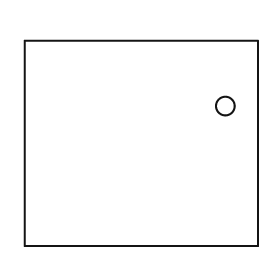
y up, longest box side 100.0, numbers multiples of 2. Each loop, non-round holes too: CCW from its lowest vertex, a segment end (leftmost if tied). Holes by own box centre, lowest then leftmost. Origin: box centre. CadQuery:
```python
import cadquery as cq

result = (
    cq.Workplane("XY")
    .moveTo(-50.0, -44.0)
    .lineTo(50.0, -44.0)
    .lineTo(50.0, 44.0)
    .lineTo(-50.0, 44.0)
    .close()
    .moveTo(36.0, 16.0)
    .circle(4.0)
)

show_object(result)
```